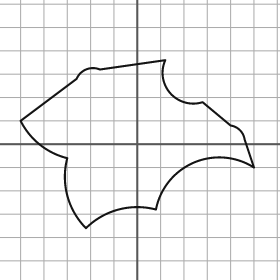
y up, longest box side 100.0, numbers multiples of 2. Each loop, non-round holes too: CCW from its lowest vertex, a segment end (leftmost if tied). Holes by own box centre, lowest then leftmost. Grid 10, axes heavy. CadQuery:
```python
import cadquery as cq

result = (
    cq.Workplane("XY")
    .moveTo(-22.0, -36.0)
    .threePointArc((-8.0, -28.0), (8.0, -28.0))
    .threePointArc((24.0, -8.0), (50.0, -10.0))
    .lineTo(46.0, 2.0)
    .threePointArc((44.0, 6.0), (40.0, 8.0))
    .lineTo(28.0, 18.0)
    .threePointArc((14.0, 22.0), (12.0, 36.0))
    .lineTo(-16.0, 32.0)
    .threePointArc((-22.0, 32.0), (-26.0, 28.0))
    .lineTo(-50.0, 10.0)
    .threePointArc((-42.0, 0.0), (-30.0, -6.0))
    .threePointArc((-30.0, -22.0), (-22.0, -36.0))
    .close()
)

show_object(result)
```